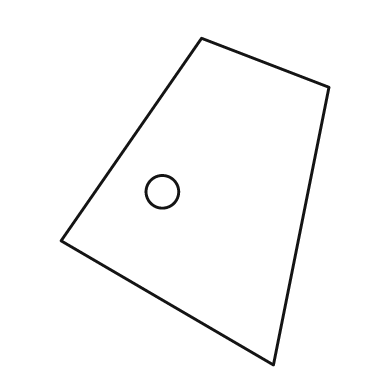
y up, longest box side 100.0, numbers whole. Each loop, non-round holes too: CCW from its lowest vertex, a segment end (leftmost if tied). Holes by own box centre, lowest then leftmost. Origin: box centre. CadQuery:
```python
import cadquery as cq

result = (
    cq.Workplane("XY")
    .moveTo(24.0, -50.0)
    .lineTo(41.0, 35.0)
    .lineTo(2.0, 50.0)
    .lineTo(-41.0, -12.0)
    .close()
    .moveTo(-10.0, 3.0)
    .circle(5.0)
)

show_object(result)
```